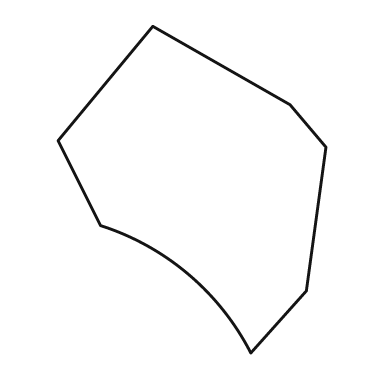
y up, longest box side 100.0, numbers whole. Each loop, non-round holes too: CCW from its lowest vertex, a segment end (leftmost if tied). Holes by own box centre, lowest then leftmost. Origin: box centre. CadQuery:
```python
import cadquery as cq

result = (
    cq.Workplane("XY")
    .moveTo(18.0, -50.0)
    .lineTo(35.0, -31.0)
    .lineTo(41.0, 13.0)
    .lineTo(30.0, 26.0)
    .lineTo(-12.0, 50.0)
    .lineTo(-41.0, 15.0)
    .lineTo(-28.0, -11.0)
    .threePointArc((-1.0, -26.0), (18.0, -50.0))
    .close()
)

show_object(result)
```